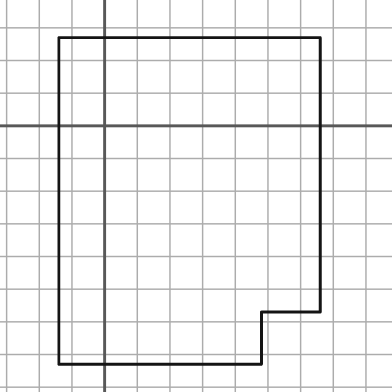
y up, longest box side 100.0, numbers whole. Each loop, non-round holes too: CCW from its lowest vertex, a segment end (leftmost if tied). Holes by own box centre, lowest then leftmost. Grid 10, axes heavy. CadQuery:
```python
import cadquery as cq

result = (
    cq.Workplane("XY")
    .moveTo(-14.0, -73.0)
    .lineTo(48.0, -73.0)
    .lineTo(48.0, -57.0)
    .lineTo(66.0, -57.0)
    .lineTo(66.0, 27.0)
    .lineTo(-14.0, 27.0)
    .close()
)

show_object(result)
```